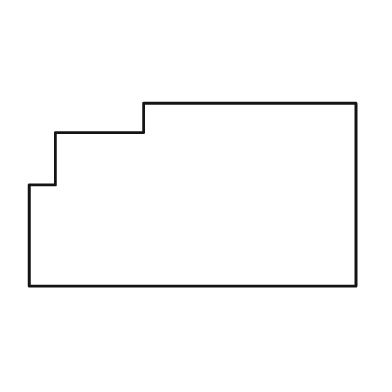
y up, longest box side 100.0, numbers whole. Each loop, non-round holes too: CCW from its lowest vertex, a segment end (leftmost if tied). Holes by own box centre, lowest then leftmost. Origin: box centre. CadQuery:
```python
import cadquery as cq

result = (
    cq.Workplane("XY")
    .moveTo(-50.0, -28.0)
    .lineTo(50.0, -28.0)
    .lineTo(50.0, 28.0)
    .lineTo(-15.0, 28.0)
    .lineTo(-15.0, 19.0)
    .lineTo(-42.0, 19.0)
    .lineTo(-42.0, 3.0)
    .lineTo(-50.0, 3.0)
    .close()
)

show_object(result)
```